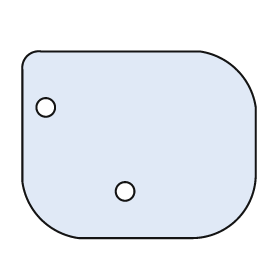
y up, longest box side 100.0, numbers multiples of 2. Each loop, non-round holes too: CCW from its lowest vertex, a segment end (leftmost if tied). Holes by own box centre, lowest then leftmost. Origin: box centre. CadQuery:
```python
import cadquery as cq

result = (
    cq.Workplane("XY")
    .moveTo(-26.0, -40.0)
    .lineTo(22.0, -40.0)
    .threePointArc((42.0, -32.0), (50.0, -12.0))
    .lineTo(50.0, 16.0)
    .threePointArc((42.0, 32.0), (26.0, 40.0))
    .lineTo(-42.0, 40.0)
    .threePointArc((-48.0, 38.0), (-50.0, 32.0))
    .lineTo(-50.0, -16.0)
    .threePointArc((-42.0, -32.0), (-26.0, -40.0))
    .close()
    .moveTo(-6.0, -20.0)
    .circle(4.0)
    .moveTo(-40.0, 16.0)
    .circle(4.0)
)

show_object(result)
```